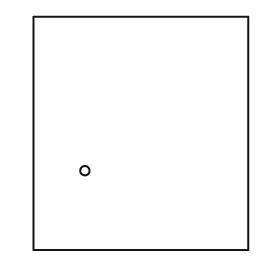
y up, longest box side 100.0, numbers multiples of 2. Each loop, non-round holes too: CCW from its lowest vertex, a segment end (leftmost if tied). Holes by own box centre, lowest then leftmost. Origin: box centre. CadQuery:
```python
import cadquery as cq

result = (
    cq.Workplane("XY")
    .moveTo(-46.0, -50.0)
    .lineTo(46.0, -50.0)
    .lineTo(46.0, 50.0)
    .lineTo(-46.0, 50.0)
    .close()
    .moveTo(-24.0, -16.0)
    .circle(2.0)
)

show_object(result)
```